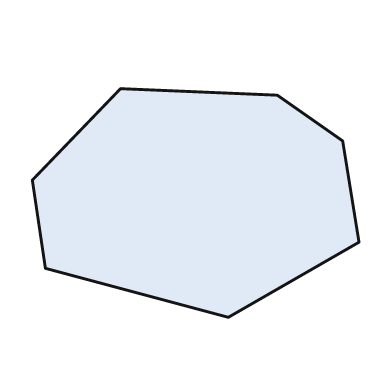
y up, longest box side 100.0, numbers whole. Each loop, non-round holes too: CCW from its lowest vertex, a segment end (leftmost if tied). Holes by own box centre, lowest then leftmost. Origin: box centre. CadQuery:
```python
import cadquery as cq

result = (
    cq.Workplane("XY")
    .moveTo(10.0, -35.0)
    .lineTo(50.0, -12.0)
    .lineTo(45.0, 19.0)
    .lineTo(25.0, 33.0)
    .lineTo(-23.0, 35.0)
    .lineTo(-50.0, 7.0)
    .lineTo(-46.0, -20.0)
    .close()
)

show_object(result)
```